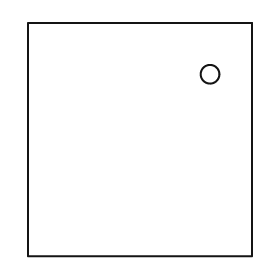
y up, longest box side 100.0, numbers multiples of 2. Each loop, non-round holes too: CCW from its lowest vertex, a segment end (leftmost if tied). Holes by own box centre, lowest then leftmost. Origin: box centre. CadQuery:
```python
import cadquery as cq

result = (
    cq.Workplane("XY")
    .moveTo(-48.0, -50.0)
    .lineTo(48.0, -50.0)
    .lineTo(48.0, 50.0)
    .lineTo(-48.0, 50.0)
    .close()
    .moveTo(30.0, 28.0)
    .circle(4.0)
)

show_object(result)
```